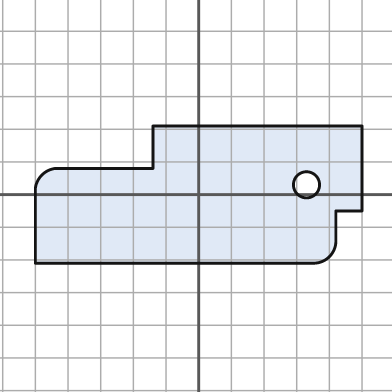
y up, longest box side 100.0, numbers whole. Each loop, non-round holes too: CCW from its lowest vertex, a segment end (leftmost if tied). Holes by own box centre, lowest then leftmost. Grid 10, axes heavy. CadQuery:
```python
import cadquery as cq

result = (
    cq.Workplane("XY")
    .moveTo(-50.0, -21.0)
    .lineTo(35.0, -21.0)
    .threePointArc((40.0, -19.0), (42.0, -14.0))
    .lineTo(42.0, -5.0)
    .lineTo(50.0, -5.0)
    .lineTo(50.0, 21.0)
    .lineTo(-14.0, 21.0)
    .lineTo(-14.0, 8.0)
    .lineTo(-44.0, 8.0)
    .threePointArc((-48.0, 6.0), (-50.0, 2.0))
    .close()
    .moveTo(33.0, 3.0)
    .circle(4.0)
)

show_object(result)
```